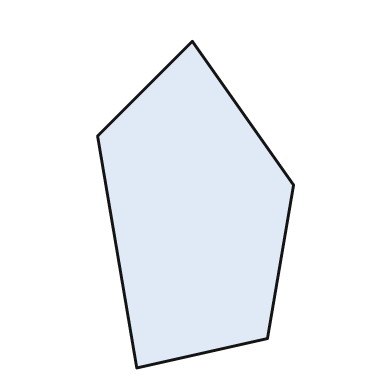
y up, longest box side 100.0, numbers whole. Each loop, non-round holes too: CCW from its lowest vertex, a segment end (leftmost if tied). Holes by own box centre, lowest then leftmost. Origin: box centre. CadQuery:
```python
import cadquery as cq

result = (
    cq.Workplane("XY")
    .moveTo(-18.0, -50.0)
    .lineTo(22.0, -41.0)
    .lineTo(30.0, 6.0)
    .lineTo(-1.0, 50.0)
    .lineTo(-30.0, 21.0)
    .close()
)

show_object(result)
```